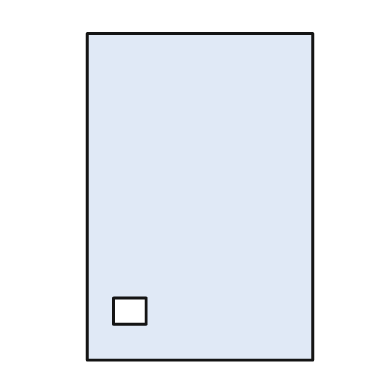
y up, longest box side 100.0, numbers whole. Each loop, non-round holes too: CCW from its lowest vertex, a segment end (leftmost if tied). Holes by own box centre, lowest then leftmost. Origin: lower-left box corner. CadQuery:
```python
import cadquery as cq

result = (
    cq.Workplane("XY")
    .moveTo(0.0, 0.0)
    .lineTo(69.0, 0.0)
    .lineTo(69.0, 100.0)
    .lineTo(0.0, 100.0)
    .close()
    .moveTo(8.0, 11.0)
    .lineTo(18.0, 11.0)
    .lineTo(18.0, 19.0)
    .lineTo(8.0, 19.0)
    .close()
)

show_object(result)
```